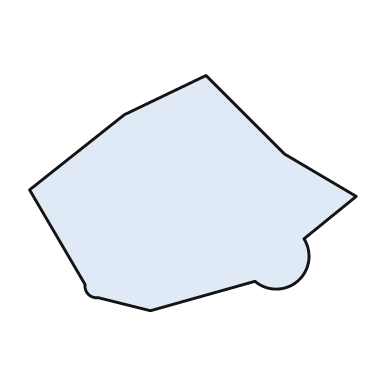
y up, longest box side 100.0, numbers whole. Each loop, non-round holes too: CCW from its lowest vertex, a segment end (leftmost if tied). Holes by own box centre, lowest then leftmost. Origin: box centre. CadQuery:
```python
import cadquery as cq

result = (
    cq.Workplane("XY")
    .moveTo(-13.0, -36.0)
    .lineTo(19.0, -27.0)
    .threePointArc((32.0, -27.0), (34.0, -14.0))
    .lineTo(50.0, -1.0)
    .lineTo(28.0, 12.0)
    .lineTo(4.0, 36.0)
    .lineTo(-21.0, 24.0)
    .lineTo(-50.0, 1.0)
    .lineTo(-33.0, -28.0)
    .threePointArc((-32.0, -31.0), (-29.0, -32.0))
    .close()
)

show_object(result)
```